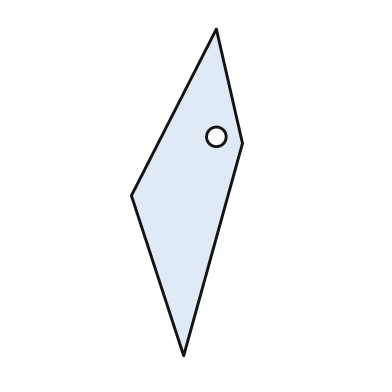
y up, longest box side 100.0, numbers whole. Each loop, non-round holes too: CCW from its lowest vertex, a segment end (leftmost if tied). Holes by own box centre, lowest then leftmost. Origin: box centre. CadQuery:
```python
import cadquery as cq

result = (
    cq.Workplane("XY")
    .moveTo(-1.0, -50.0)
    .lineTo(17.0, 15.0)
    .lineTo(9.0, 50.0)
    .lineTo(-17.0, -1.0)
    .close()
    .moveTo(9.0, 17.0)
    .circle(3.0)
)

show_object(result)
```